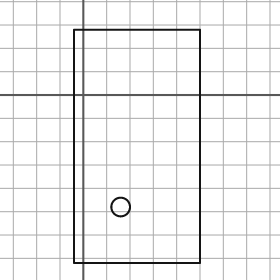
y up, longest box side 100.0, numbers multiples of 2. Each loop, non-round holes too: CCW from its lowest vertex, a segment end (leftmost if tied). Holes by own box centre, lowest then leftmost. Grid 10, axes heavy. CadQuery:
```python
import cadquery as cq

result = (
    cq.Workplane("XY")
    .moveTo(-4.0, -72.0)
    .lineTo(50.0, -72.0)
    .lineTo(50.0, 28.0)
    .lineTo(-4.0, 28.0)
    .close()
    .moveTo(16.0, -48.0)
    .circle(4.0)
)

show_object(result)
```